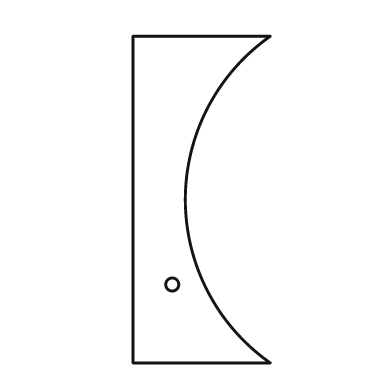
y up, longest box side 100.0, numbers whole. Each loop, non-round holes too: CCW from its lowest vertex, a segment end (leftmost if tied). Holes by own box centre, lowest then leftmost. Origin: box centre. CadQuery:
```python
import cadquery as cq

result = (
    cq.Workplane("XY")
    .moveTo(-21.0, -50.0)
    .lineTo(21.0, -50.0)
    .threePointArc((-5.0, 0.0), (21.0, 50.0))
    .lineTo(-21.0, 50.0)
    .close()
    .moveTo(-9.0, -26.0)
    .circle(2.0)
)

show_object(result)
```